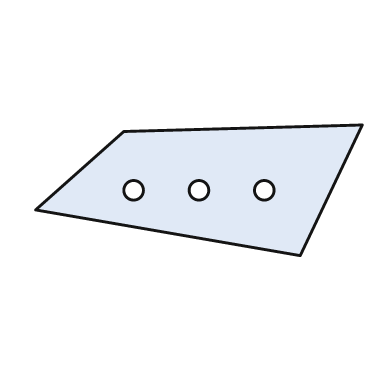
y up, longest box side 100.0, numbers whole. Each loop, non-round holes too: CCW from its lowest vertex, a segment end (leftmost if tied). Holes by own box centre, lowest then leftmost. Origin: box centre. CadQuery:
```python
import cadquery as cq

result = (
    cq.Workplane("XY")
    .moveTo(31.0, -20.0)
    .lineTo(50.0, 20.0)
    .lineTo(-23.0, 18.0)
    .lineTo(-50.0, -6.0)
    .close()
    .moveTo(-20.0, 0.0)
    .circle(3.0)
    .moveTo(0.0, 0.0)
    .circle(3.0)
    .moveTo(20.0, 0.0)
    .circle(3.0)
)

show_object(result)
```